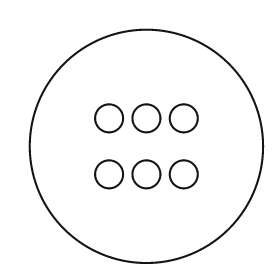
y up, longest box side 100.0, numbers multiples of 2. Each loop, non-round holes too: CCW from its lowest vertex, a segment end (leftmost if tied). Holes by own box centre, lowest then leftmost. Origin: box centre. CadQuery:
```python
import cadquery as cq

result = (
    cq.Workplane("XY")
    .moveTo(0.0, 0.0)
    .circle(50.0)
    .moveTo(-16.0, -12.0)
    .circle(6.0)
    .moveTo(0.0, -12.0)
    .circle(6.0)
    .moveTo(16.0, -12.0)
    .circle(6.0)
    .moveTo(-16.0, 12.0)
    .circle(6.0)
    .moveTo(0.0, 12.0)
    .circle(6.0)
    .moveTo(16.0, 12.0)
    .circle(6.0)
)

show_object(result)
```